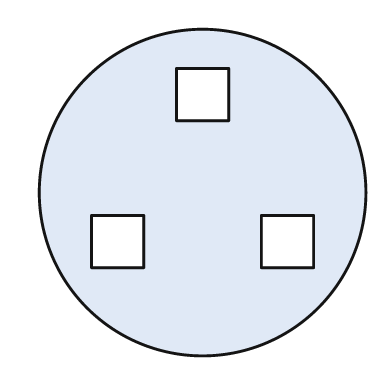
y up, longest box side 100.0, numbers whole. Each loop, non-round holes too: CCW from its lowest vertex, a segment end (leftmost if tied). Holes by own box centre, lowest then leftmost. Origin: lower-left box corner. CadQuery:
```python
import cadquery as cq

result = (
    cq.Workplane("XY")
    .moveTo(50.0, 50.0)
    .circle(50.0)
    .moveTo(16.0, 27.0)
    .lineTo(32.0, 27.0)
    .lineTo(32.0, 43.0)
    .lineTo(16.0, 43.0)
    .close()
    .moveTo(68.0, 27.0)
    .lineTo(84.0, 27.0)
    .lineTo(84.0, 43.0)
    .lineTo(68.0, 43.0)
    .close()
    .moveTo(42.0, 72.0)
    .lineTo(58.0, 72.0)
    .lineTo(58.0, 88.0)
    .lineTo(42.0, 88.0)
    .close()
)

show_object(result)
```